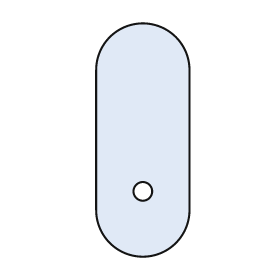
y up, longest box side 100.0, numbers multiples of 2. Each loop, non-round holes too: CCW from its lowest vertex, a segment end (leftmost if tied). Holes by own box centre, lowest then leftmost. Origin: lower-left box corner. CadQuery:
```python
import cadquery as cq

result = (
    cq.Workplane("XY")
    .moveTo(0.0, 20.0)
    .threePointArc((20.0, 0.0), (40.0, 20.0))
    .lineTo(40.0, 80.0)
    .threePointArc((20.0, 100.0), (0.0, 80.0))
    .close()
    .moveTo(20.0, 28.0)
    .circle(4.0)
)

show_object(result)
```